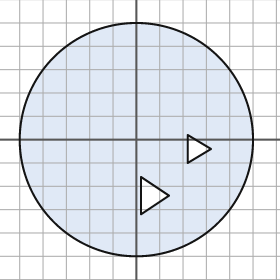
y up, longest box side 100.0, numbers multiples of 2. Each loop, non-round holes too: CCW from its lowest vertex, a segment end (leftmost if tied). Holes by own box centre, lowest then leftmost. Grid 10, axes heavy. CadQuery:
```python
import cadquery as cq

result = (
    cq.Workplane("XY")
    .moveTo(0.0, 0.0)
    .circle(50.0)
    .moveTo(2.0, -32.0)
    .lineTo(14.0, -24.0)
    .lineTo(2.0, -16.0)
    .close()
    .moveTo(22.0, -10.0)
    .lineTo(32.0, -4.0)
    .lineTo(22.0, 2.0)
    .close()
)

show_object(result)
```